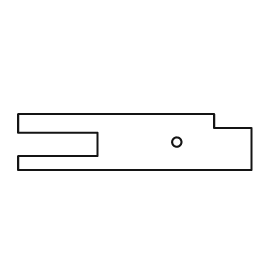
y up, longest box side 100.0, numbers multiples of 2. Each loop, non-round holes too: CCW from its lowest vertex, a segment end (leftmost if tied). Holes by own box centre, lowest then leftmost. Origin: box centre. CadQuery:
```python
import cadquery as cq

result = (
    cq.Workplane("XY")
    .moveTo(-50.0, -12.0)
    .lineTo(50.0, -12.0)
    .lineTo(50.0, 6.0)
    .lineTo(34.0, 6.0)
    .lineTo(34.0, 12.0)
    .lineTo(-50.0, 12.0)
    .lineTo(-50.0, 4.0)
    .lineTo(-16.0, 4.0)
    .lineTo(-16.0, -6.0)
    .lineTo(-50.0, -6.0)
    .close()
    .moveTo(18.0, 0.0)
    .circle(2.0)
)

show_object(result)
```